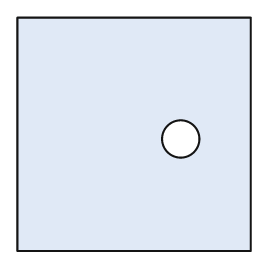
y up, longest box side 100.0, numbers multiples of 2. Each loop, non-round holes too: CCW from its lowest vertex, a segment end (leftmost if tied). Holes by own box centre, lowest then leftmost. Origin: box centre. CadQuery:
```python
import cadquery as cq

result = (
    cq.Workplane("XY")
    .moveTo(-50.0, -50.0)
    .lineTo(50.0, -50.0)
    .lineTo(50.0, 50.0)
    .lineTo(-50.0, 50.0)
    .close()
    .moveTo(20.0, -2.0)
    .circle(8.0)
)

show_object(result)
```